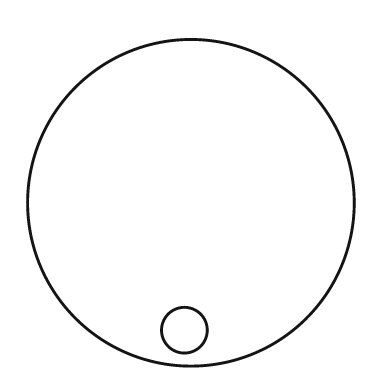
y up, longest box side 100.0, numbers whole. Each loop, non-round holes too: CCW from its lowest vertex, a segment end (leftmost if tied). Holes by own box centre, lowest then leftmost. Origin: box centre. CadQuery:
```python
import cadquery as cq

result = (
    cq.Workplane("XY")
    .moveTo(0.0, 0.0)
    .circle(50.0)
    .moveTo(-2.0, -39.0)
    .circle(7.0)
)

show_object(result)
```